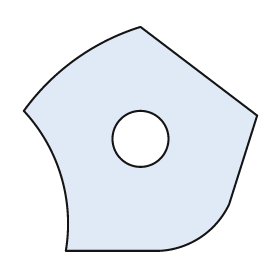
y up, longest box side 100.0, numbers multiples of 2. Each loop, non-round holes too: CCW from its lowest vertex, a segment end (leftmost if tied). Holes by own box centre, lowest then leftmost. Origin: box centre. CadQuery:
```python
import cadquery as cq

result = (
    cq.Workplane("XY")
    .moveTo(-32.0, -48.0)
    .lineTo(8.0, -48.0)
    .threePointArc((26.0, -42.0), (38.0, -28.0))
    .lineTo(50.0, 10.0)
    .lineTo(0.0, 48.0)
    .threePointArc((-28.0, 34.0), (-50.0, 12.0))
    .threePointArc((-34.0, -16.0), (-32.0, -48.0))
    .close()
    .moveTo(0.0, 0.0)
    .circle(12.0)
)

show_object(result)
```